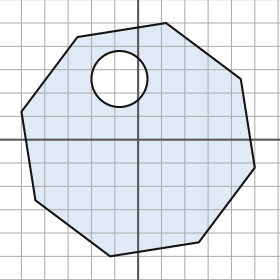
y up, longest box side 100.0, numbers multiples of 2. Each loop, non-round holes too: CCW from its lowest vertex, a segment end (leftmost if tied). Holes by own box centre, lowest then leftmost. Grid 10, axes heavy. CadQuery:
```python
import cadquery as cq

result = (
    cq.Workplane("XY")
    .moveTo(-12.0, -50.0)
    .lineTo(26.0, -44.0)
    .lineTo(50.0, -12.0)
    .lineTo(44.0, 26.0)
    .lineTo(12.0, 50.0)
    .lineTo(-26.0, 44.0)
    .lineTo(-50.0, 12.0)
    .lineTo(-44.0, -26.0)
    .close()
    .moveTo(-8.0, 26.0)
    .circle(12.0)
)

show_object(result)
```